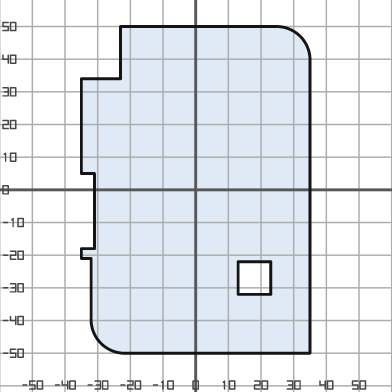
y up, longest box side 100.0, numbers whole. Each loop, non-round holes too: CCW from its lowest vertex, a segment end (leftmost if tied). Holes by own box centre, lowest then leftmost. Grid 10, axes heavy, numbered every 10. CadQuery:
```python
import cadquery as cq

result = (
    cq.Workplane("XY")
    .moveTo(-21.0, -50.0)
    .lineTo(35.0, -50.0)
    .lineTo(35.0, 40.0)
    .threePointArc((32.0, 47.0), (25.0, 50.0))
    .lineTo(-23.0, 50.0)
    .lineTo(-23.0, 34.0)
    .lineTo(-35.0, 34.0)
    .lineTo(-35.0, 5.0)
    .lineTo(-31.0, 5.0)
    .lineTo(-31.0, -18.0)
    .lineTo(-35.0, -18.0)
    .lineTo(-35.0, -21.0)
    .lineTo(-32.0, -21.0)
    .lineTo(-32.0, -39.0)
    .threePointArc((-29.0, -47.0), (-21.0, -50.0))
    .close()
    .moveTo(13.0, -32.0)
    .lineTo(23.0, -32.0)
    .lineTo(23.0, -22.0)
    .lineTo(13.0, -22.0)
    .close()
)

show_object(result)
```